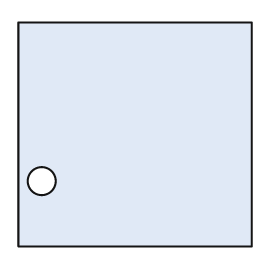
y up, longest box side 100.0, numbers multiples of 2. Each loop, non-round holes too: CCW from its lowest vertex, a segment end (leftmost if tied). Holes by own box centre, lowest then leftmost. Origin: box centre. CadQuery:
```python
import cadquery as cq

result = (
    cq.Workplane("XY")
    .moveTo(-50.0, -48.0)
    .lineTo(50.0, -48.0)
    .lineTo(50.0, 48.0)
    .lineTo(-50.0, 48.0)
    .close()
    .moveTo(-40.0, -20.0)
    .circle(6.0)
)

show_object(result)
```